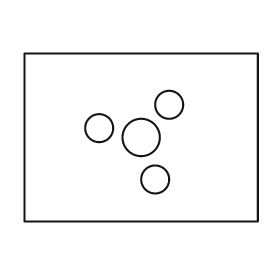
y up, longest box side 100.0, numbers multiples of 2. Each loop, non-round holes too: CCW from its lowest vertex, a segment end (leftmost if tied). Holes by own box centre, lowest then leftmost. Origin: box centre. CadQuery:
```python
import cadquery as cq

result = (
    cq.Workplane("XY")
    .moveTo(-50.0, -36.0)
    .lineTo(50.0, -36.0)
    .lineTo(50.0, 36.0)
    .lineTo(-50.0, 36.0)
    .close()
    .moveTo(6.0, -18.0)
    .circle(6.0)
    .moveTo(0.0, 0.0)
    .circle(8.0)
    .moveTo(-18.0, 4.0)
    .circle(6.0)
    .moveTo(12.0, 14.0)
    .circle(6.0)
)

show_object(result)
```